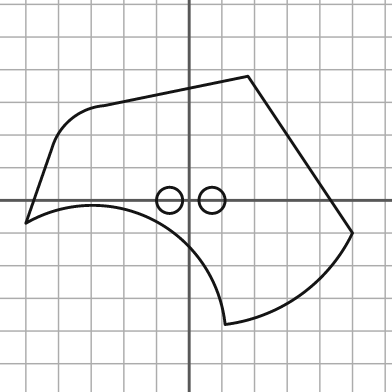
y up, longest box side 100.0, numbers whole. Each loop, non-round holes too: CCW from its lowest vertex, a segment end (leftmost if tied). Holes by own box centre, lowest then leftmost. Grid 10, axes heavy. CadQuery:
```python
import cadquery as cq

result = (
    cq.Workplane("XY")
    .moveTo(11.0, -38.0)
    .threePointArc((34.0, -29.0), (50.0, -10.0))
    .lineTo(18.0, 38.0)
    .lineTo(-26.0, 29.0)
    .threePointArc((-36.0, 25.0), (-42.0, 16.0))
    .lineTo(-50.0, -7.0)
    .threePointArc((-11.0, -6.0), (11.0, -38.0))
    .close()
    .moveTo(-6.0, 0.0)
    .circle(4.0)
    .moveTo(7.0, 0.0)
    .circle(4.0)
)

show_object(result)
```